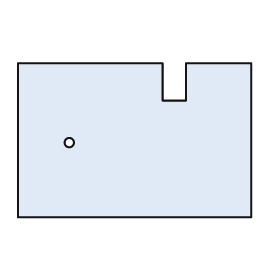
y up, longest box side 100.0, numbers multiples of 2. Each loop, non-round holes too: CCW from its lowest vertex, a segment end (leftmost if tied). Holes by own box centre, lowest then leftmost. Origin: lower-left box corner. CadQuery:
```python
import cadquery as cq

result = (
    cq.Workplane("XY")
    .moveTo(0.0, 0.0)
    .lineTo(100.0, 0.0)
    .lineTo(100.0, 66.0)
    .lineTo(72.0, 66.0)
    .lineTo(72.0, 50.0)
    .lineTo(62.0, 50.0)
    .lineTo(62.0, 66.0)
    .lineTo(0.0, 66.0)
    .close()
    .moveTo(22.0, 32.0)
    .circle(2.0)
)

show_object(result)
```